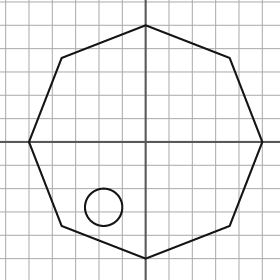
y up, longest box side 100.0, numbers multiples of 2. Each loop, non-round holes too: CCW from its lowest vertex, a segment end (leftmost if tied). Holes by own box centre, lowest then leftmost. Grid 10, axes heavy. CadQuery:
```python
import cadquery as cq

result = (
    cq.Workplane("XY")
    .moveTo(0.0, -50.0)
    .lineTo(36.0, -36.0)
    .lineTo(50.0, 0.0)
    .lineTo(36.0, 36.0)
    .lineTo(0.0, 50.0)
    .lineTo(-36.0, 36.0)
    .lineTo(-50.0, 0.0)
    .lineTo(-36.0, -36.0)
    .close()
    .moveTo(-18.0, -28.0)
    .circle(8.0)
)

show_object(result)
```